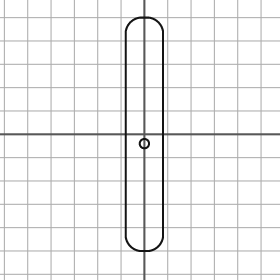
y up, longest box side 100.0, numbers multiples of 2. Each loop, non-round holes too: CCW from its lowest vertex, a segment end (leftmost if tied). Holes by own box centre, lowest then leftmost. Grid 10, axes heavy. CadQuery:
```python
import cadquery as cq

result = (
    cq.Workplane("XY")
    .moveTo(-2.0, -50.0)
    .lineTo(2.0, -50.0)
    .threePointArc((6.0, -48.0), (8.0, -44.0))
    .lineTo(8.0, 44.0)
    .threePointArc((6.0, 48.0), (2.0, 50.0))
    .lineTo(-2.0, 50.0)
    .threePointArc((-6.0, 48.0), (-8.0, 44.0))
    .lineTo(-8.0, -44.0)
    .threePointArc((-6.0, -48.0), (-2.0, -50.0))
    .close()
    .moveTo(0.0, -4.0)
    .circle(2.0)
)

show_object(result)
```